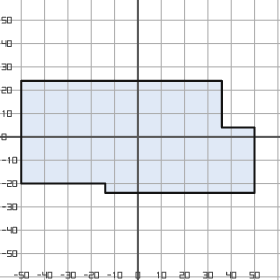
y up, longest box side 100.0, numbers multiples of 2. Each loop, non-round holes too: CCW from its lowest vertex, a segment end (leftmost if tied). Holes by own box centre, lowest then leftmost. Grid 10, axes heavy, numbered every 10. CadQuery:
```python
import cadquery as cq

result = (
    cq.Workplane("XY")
    .moveTo(-14.0, -24.0)
    .lineTo(50.0, -24.0)
    .lineTo(50.0, 4.0)
    .lineTo(36.0, 4.0)
    .lineTo(36.0, 24.0)
    .lineTo(-50.0, 24.0)
    .lineTo(-50.0, -20.0)
    .lineTo(-14.0, -20.0)
    .close()
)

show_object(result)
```